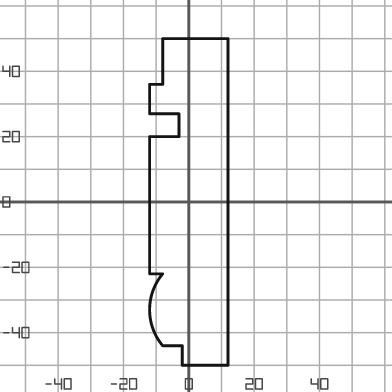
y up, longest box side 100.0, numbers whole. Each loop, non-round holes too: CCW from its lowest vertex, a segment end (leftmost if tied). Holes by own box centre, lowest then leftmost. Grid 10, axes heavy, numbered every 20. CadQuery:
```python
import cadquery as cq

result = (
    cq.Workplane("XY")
    .moveTo(-2.0, -50.0)
    .lineTo(12.0, -50.0)
    .lineTo(12.0, 50.0)
    .lineTo(-8.0, 50.0)
    .lineTo(-8.0, 36.0)
    .lineTo(-12.0, 36.0)
    .lineTo(-12.0, 27.0)
    .lineTo(-3.0, 27.0)
    .lineTo(-3.0, 20.0)
    .lineTo(-12.0, 20.0)
    .lineTo(-12.0, -22.0)
    .lineTo(-8.0, -22.0)
    .threePointArc((-12.0, -33.0), (-8.0, -44.0))
    .lineTo(-2.0, -44.0)
    .close()
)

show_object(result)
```